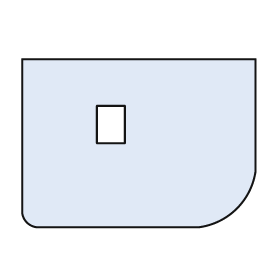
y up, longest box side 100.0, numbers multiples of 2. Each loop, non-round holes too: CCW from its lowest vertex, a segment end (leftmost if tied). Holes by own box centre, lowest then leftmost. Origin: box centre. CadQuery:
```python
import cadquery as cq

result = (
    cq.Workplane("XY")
    .moveTo(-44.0, -36.0)
    .lineTo(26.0, -36.0)
    .threePointArc((42.0, -28.0), (50.0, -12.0))
    .lineTo(50.0, 36.0)
    .lineTo(-50.0, 36.0)
    .lineTo(-50.0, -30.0)
    .threePointArc((-48.0, -34.0), (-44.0, -36.0))
    .close()
    .moveTo(-18.0, 0.0)
    .lineTo(-6.0, 0.0)
    .lineTo(-6.0, 16.0)
    .lineTo(-18.0, 16.0)
    .close()
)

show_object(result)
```